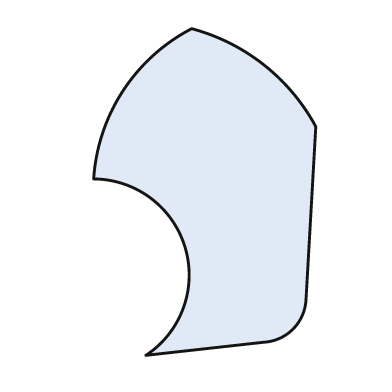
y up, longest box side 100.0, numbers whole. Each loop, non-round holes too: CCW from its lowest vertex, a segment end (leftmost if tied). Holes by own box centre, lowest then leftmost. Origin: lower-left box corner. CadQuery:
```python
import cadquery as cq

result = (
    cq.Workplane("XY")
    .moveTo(16.0, 0.0)
    .lineTo(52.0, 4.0)
    .threePointArc((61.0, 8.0), (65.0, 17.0))
    .lineTo(68.0, 70.0)
    .threePointArc((52.0, 89.0), (30.0, 100.0))
    .threePointArc((9.0, 81.0), (0.0, 54.0))
    .threePointArc((28.0, 33.0), (16.0, 0.0))
    .close()
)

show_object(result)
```